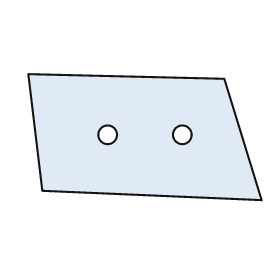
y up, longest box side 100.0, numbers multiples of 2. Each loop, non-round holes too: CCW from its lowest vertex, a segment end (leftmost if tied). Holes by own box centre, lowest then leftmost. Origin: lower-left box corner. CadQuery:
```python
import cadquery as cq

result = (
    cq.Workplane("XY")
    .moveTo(100.0, 0.0)
    .lineTo(84.0, 52.0)
    .lineTo(0.0, 54.0)
    .lineTo(6.0, 4.0)
    .close()
    .moveTo(34.0, 28.0)
    .circle(4.0)
    .moveTo(66.0, 28.0)
    .circle(4.0)
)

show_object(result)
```